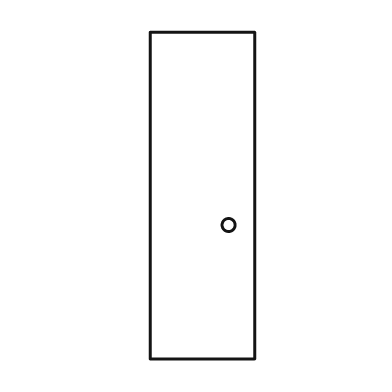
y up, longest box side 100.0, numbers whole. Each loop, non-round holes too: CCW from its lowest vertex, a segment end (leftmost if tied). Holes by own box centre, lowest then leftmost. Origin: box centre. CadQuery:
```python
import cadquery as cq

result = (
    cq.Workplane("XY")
    .moveTo(-16.0, -50.0)
    .lineTo(16.0, -50.0)
    .lineTo(16.0, 50.0)
    .lineTo(-16.0, 50.0)
    .close()
    .moveTo(8.0, -9.0)
    .circle(2.0)
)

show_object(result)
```